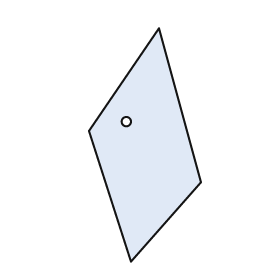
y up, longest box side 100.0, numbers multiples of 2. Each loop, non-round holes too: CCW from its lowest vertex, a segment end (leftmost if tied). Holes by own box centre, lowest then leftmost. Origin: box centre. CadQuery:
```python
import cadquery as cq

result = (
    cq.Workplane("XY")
    .moveTo(-6.0, -50.0)
    .lineTo(24.0, -16.0)
    .lineTo(6.0, 50.0)
    .lineTo(-24.0, 6.0)
    .close()
    .moveTo(-8.0, 10.0)
    .circle(2.0)
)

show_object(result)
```